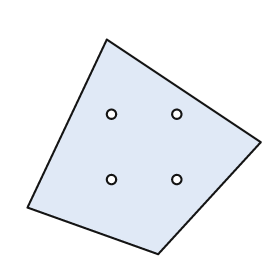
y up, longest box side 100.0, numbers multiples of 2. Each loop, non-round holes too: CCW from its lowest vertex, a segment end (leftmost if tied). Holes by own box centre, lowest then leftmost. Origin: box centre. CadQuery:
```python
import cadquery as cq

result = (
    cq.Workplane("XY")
    .moveTo(6.0, -46.0)
    .lineTo(50.0, 2.0)
    .lineTo(-16.0, 46.0)
    .lineTo(-50.0, -26.0)
    .close()
    .moveTo(-14.0, -14.0)
    .circle(2.0)
    .moveTo(14.0, -14.0)
    .circle(2.0)
    .moveTo(-14.0, 14.0)
    .circle(2.0)
    .moveTo(14.0, 14.0)
    .circle(2.0)
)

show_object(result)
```